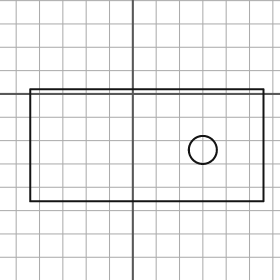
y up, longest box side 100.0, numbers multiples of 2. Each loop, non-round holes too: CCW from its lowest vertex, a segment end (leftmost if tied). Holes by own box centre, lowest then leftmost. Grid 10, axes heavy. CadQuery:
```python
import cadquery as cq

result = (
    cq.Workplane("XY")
    .moveTo(-44.0, -46.0)
    .lineTo(56.0, -46.0)
    .lineTo(56.0, 2.0)
    .lineTo(-44.0, 2.0)
    .close()
    .moveTo(30.0, -24.0)
    .circle(6.0)
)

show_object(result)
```